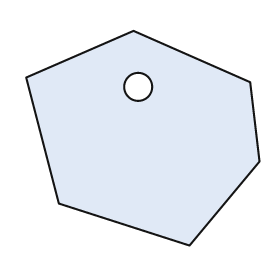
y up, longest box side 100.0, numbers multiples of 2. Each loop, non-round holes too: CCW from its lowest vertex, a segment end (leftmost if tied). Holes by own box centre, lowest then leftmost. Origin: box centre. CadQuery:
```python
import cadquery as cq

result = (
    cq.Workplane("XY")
    .moveTo(20.0, -46.0)
    .lineTo(50.0, -10.0)
    .lineTo(46.0, 24.0)
    .lineTo(-4.0, 46.0)
    .lineTo(-50.0, 26.0)
    .lineTo(-36.0, -28.0)
    .close()
    .moveTo(-2.0, 22.0)
    .circle(6.0)
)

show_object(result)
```